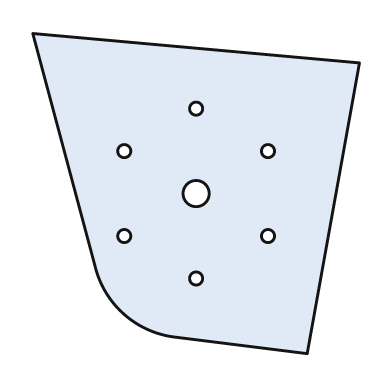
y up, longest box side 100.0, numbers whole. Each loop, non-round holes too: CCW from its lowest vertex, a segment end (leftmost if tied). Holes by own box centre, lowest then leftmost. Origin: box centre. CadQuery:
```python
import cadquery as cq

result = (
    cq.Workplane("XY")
    .moveTo(34.0, -49.0)
    .lineTo(50.0, 40.0)
    .lineTo(-50.0, 49.0)
    .lineTo(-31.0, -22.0)
    .threePointArc((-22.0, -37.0), (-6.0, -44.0))
    .close()
    .moveTo(0.0, -26.0)
    .circle(2.0)
    .moveTo(-22.0, -13.0)
    .circle(2.0)
    .moveTo(22.0, -13.0)
    .circle(2.0)
    .moveTo(0.0, 0.0)
    .circle(4.0)
    .moveTo(-22.0, 13.0)
    .circle(2.0)
    .moveTo(22.0, 13.0)
    .circle(2.0)
    .moveTo(0.0, 26.0)
    .circle(2.0)
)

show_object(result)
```